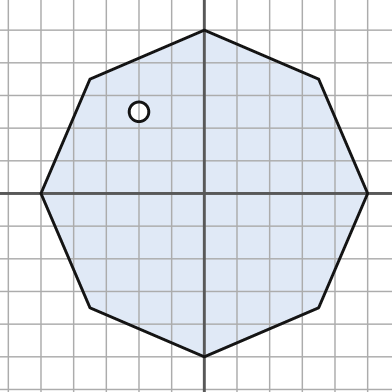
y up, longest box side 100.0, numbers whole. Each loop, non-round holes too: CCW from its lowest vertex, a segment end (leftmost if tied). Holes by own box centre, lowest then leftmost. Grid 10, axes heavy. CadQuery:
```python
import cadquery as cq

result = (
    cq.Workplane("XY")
    .moveTo(0.0, -50.0)
    .lineTo(35.0, -35.0)
    .lineTo(50.0, 0.0)
    .lineTo(35.0, 35.0)
    .lineTo(0.0, 50.0)
    .lineTo(-35.0, 35.0)
    .lineTo(-50.0, 0.0)
    .lineTo(-35.0, -35.0)
    .close()
    .moveTo(-20.0, 25.0)
    .circle(3.0)
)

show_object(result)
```